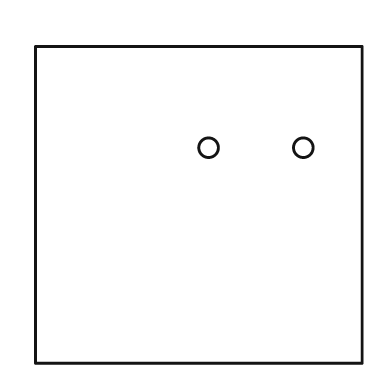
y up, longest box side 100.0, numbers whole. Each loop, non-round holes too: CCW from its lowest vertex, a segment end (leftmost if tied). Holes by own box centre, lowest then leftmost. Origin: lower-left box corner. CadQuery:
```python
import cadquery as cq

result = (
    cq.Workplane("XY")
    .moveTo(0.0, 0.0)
    .lineTo(100.0, 0.0)
    .lineTo(100.0, 97.0)
    .lineTo(0.0, 97.0)
    .close()
    .moveTo(53.0, 66.0)
    .circle(3.0)
    .moveTo(82.0, 66.0)
    .circle(3.0)
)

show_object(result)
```